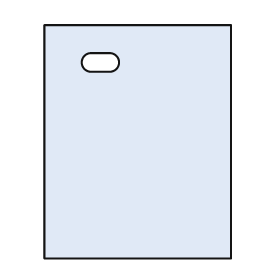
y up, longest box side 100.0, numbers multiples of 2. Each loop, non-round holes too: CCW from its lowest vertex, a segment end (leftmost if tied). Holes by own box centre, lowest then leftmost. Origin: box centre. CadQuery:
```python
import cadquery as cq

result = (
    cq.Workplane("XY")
    .moveTo(-40.0, -50.0)
    .lineTo(40.0, -50.0)
    .lineTo(40.0, 50.0)
    .lineTo(-40.0, 50.0)
    .close()
    .moveTo(-20.0, 30.0)
    .lineTo(-12.0, 30.0)
    .threePointArc((-8.0, 34.0), (-12.0, 38.0))
    .lineTo(-20.0, 38.0)
    .threePointArc((-24.0, 34.0), (-20.0, 30.0))
    .close()
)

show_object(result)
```